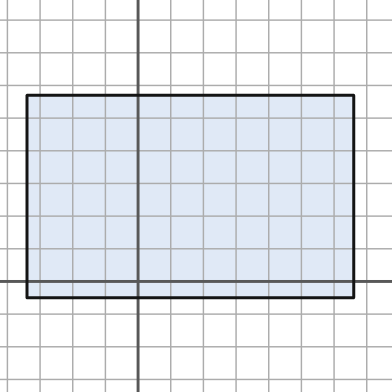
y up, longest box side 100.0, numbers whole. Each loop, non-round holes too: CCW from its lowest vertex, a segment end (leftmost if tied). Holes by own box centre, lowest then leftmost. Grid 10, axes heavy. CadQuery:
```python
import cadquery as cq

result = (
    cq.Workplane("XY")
    .moveTo(-34.0, -5.0)
    .lineTo(66.0, -5.0)
    .lineTo(66.0, 57.0)
    .lineTo(-34.0, 57.0)
    .close()
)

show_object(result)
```